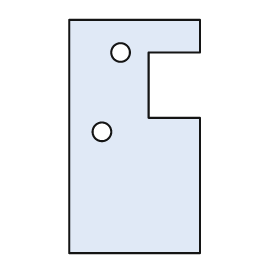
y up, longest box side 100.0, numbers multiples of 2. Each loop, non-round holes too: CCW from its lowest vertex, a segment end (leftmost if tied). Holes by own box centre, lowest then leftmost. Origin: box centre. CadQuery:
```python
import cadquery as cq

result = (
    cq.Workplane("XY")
    .moveTo(-28.0, -50.0)
    .lineTo(28.0, -50.0)
    .lineTo(28.0, 8.0)
    .lineTo(6.0, 8.0)
    .lineTo(6.0, 36.0)
    .lineTo(28.0, 36.0)
    .lineTo(28.0, 50.0)
    .lineTo(-28.0, 50.0)
    .close()
    .moveTo(-14.0, 2.0)
    .circle(4.0)
    .moveTo(-6.0, 36.0)
    .circle(4.0)
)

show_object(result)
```